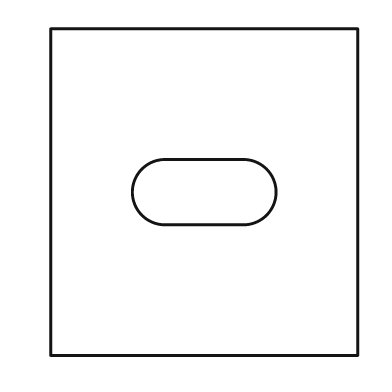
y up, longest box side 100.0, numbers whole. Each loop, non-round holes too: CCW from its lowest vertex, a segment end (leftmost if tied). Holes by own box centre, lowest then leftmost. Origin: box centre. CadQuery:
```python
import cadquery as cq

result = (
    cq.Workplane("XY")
    .moveTo(-47.0, -50.0)
    .lineTo(47.0, -50.0)
    .lineTo(47.0, 50.0)
    .lineTo(-47.0, 50.0)
    .close()
    .moveTo(-12.0, -10.0)
    .lineTo(12.0, -10.0)
    .threePointArc((22.0, 0.0), (12.0, 10.0))
    .lineTo(-12.0, 10.0)
    .threePointArc((-22.0, 0.0), (-12.0, -10.0))
    .close()
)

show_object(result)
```